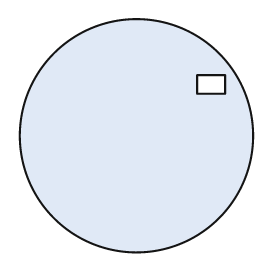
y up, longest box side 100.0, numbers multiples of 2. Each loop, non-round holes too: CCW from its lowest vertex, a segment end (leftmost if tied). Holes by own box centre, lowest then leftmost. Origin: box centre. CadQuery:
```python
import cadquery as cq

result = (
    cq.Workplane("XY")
    .moveTo(0.0, 0.0)
    .circle(50.0)
    .moveTo(26.0, 18.0)
    .lineTo(38.0, 18.0)
    .lineTo(38.0, 26.0)
    .lineTo(26.0, 26.0)
    .close()
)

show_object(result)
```